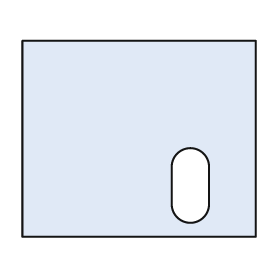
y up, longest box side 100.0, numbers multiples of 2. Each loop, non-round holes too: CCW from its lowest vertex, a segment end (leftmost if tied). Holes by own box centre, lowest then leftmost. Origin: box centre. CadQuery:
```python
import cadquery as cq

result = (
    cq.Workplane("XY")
    .moveTo(-50.0, -42.0)
    .lineTo(50.0, -42.0)
    .lineTo(50.0, 42.0)
    .lineTo(-50.0, 42.0)
    .close()
    .moveTo(14.0, -28.0)
    .threePointArc((22.0, -36.0), (30.0, -28.0))
    .lineTo(30.0, -12.0)
    .threePointArc((22.0, -4.0), (14.0, -12.0))
    .close()
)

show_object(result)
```